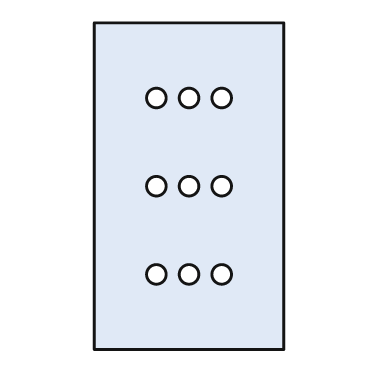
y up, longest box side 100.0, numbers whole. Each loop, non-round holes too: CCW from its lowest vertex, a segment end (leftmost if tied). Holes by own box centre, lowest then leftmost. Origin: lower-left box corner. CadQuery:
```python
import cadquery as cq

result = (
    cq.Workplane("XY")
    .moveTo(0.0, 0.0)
    .lineTo(58.0, 0.0)
    .lineTo(58.0, 100.0)
    .lineTo(0.0, 100.0)
    .close()
    .moveTo(19.0, 23.0)
    .circle(3.0)
    .moveTo(29.0, 23.0)
    .circle(3.0)
    .moveTo(39.0, 23.0)
    .circle(3.0)
    .moveTo(19.0, 50.0)
    .circle(3.0)
    .moveTo(29.0, 50.0)
    .circle(3.0)
    .moveTo(39.0, 50.0)
    .circle(3.0)
    .moveTo(19.0, 77.0)
    .circle(3.0)
    .moveTo(29.0, 77.0)
    .circle(3.0)
    .moveTo(39.0, 77.0)
    .circle(3.0)
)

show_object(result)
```